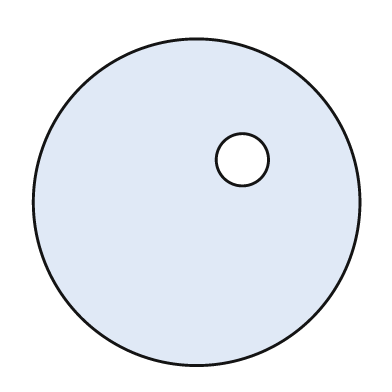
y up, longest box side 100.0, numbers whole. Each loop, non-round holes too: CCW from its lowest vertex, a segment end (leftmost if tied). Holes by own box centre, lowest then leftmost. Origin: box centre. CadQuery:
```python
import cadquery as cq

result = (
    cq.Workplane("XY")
    .moveTo(0.0, 0.0)
    .circle(50.0)
    .moveTo(14.0, 13.0)
    .circle(8.0)
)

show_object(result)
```